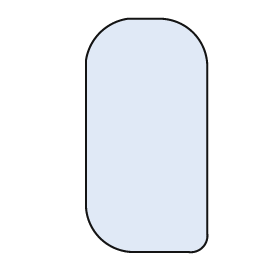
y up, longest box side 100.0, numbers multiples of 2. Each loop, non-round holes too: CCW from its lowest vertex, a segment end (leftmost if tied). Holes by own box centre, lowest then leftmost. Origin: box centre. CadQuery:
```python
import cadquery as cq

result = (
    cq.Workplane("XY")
    .moveTo(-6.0, -50.0)
    .lineTo(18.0, -50.0)
    .threePointArc((24.0, -48.0), (26.0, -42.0))
    .lineTo(26.0, 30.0)
    .threePointArc((20.0, 44.0), (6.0, 50.0))
    .lineTo(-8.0, 50.0)
    .threePointArc((-20.0, 44.0), (-26.0, 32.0))
    .lineTo(-26.0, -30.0)
    .threePointArc((-20.0, -44.0), (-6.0, -50.0))
    .close()
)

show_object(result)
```